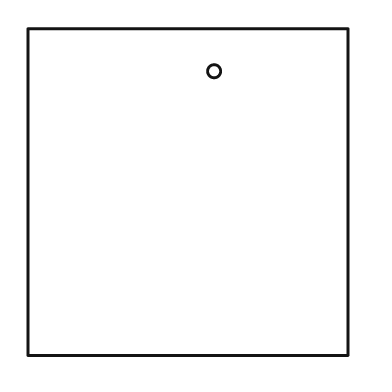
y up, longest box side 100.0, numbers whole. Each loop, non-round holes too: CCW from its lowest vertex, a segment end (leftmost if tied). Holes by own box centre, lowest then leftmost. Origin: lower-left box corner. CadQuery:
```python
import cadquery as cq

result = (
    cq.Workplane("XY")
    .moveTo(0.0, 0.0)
    .lineTo(98.0, 0.0)
    .lineTo(98.0, 100.0)
    .lineTo(0.0, 100.0)
    .close()
    .moveTo(57.0, 87.0)
    .circle(2.0)
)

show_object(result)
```